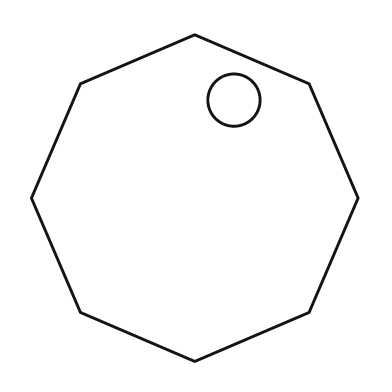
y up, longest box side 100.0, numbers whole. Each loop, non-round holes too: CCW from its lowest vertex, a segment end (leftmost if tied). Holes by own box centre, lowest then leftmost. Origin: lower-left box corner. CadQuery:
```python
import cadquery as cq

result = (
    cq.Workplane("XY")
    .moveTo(50.0, 0.0)
    .lineTo(85.0, 15.0)
    .lineTo(100.0, 50.0)
    .lineTo(85.0, 85.0)
    .lineTo(50.0, 100.0)
    .lineTo(15.0, 85.0)
    .lineTo(0.0, 50.0)
    .lineTo(15.0, 15.0)
    .close()
    .moveTo(62.0, 80.0)
    .circle(8.0)
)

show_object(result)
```